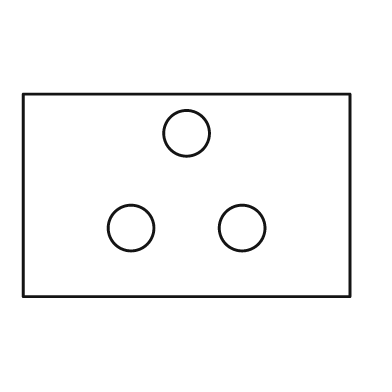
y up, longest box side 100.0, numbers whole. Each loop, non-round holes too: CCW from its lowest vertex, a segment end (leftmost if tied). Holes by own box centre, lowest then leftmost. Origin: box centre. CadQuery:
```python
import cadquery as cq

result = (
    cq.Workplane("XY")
    .moveTo(-50.0, -31.0)
    .lineTo(50.0, -31.0)
    .lineTo(50.0, 31.0)
    .lineTo(-50.0, 31.0)
    .close()
    .moveTo(-17.0, -10.0)
    .circle(7.0)
    .moveTo(17.0, -10.0)
    .circle(7.0)
    .moveTo(0.0, 19.0)
    .circle(7.0)
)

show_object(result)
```